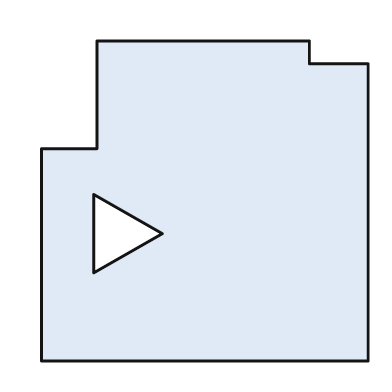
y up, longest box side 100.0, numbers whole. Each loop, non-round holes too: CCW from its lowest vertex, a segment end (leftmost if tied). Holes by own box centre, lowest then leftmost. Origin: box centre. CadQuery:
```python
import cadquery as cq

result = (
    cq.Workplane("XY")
    .moveTo(-50.0, -49.0)
    .lineTo(50.0, -49.0)
    .lineTo(50.0, 42.0)
    .lineTo(32.0, 42.0)
    .lineTo(32.0, 49.0)
    .lineTo(-33.0, 49.0)
    .lineTo(-33.0, 16.0)
    .lineTo(-50.0, 16.0)
    .close()
    .moveTo(-34.0, -22.0)
    .lineTo(-13.0, -10.0)
    .lineTo(-34.0, 2.0)
    .close()
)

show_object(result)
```